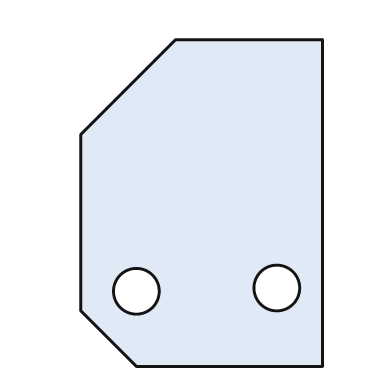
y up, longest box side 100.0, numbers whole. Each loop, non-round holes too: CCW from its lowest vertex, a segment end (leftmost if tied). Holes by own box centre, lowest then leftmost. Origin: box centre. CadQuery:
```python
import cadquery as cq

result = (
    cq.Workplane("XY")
    .moveTo(-20.0, -50.0)
    .lineTo(37.0, -50.0)
    .lineTo(37.0, 50.0)
    .lineTo(-8.0, 50.0)
    .lineTo(-37.0, 21.0)
    .lineTo(-37.0, -33.0)
    .close()
    .moveTo(-20.0, -27.0)
    .circle(7.0)
    .moveTo(23.0, -26.0)
    .circle(7.0)
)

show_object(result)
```